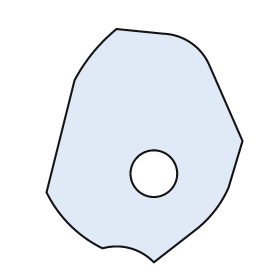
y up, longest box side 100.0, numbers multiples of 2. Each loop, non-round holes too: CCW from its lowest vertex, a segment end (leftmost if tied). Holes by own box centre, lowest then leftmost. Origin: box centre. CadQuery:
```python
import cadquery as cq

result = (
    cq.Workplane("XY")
    .moveTo(4.0, -50.0)
    .lineTo(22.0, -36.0)
    .threePointArc((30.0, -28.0), (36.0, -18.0))
    .lineTo(42.0, 2.0)
    .lineTo(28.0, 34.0)
    .threePointArc((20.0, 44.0), (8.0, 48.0))
    .lineTo(-12.0, 50.0)
    .threePointArc((-22.0, 40.0), (-30.0, 28.0))
    .lineTo(-42.0, -20.0)
    .threePointArc((-32.0, -34.0), (-18.0, -44.0))
    .threePointArc((-6.0, -44.0), (4.0, -50.0))
    .close()
    .moveTo(4.0, -12.0)
    .circle(10.0)
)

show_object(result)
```